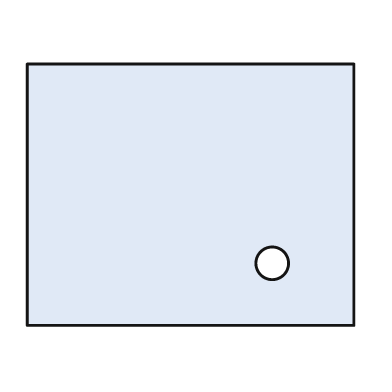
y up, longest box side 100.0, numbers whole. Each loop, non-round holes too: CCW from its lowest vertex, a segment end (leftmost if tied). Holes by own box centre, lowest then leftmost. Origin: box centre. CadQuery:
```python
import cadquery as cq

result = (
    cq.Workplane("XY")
    .moveTo(-50.0, -40.0)
    .lineTo(50.0, -40.0)
    .lineTo(50.0, 40.0)
    .lineTo(-50.0, 40.0)
    .close()
    .moveTo(25.0, -21.0)
    .circle(5.0)
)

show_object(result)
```